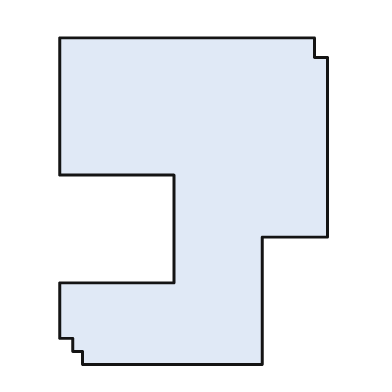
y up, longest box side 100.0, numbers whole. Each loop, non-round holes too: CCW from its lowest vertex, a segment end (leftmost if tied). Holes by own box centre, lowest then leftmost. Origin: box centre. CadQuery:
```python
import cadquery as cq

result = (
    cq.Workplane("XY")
    .moveTo(-34.0, -50.0)
    .lineTo(21.0, -50.0)
    .lineTo(21.0, -11.0)
    .lineTo(41.0, -11.0)
    .lineTo(41.0, 44.0)
    .lineTo(37.0, 44.0)
    .lineTo(37.0, 50.0)
    .lineTo(-41.0, 50.0)
    .lineTo(-41.0, 8.0)
    .lineTo(-6.0, 8.0)
    .lineTo(-6.0, -25.0)
    .lineTo(-41.0, -25.0)
    .lineTo(-41.0, -42.0)
    .lineTo(-37.0, -42.0)
    .lineTo(-37.0, -46.0)
    .lineTo(-34.0, -46.0)
    .close()
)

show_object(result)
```